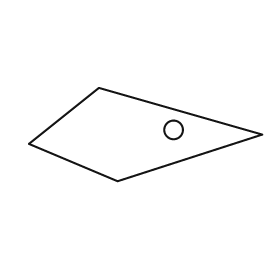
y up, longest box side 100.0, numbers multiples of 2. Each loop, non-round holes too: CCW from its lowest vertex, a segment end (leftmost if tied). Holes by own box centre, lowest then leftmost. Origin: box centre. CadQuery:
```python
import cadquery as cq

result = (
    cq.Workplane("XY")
    .moveTo(-12.0, -20.0)
    .lineTo(50.0, 0.0)
    .lineTo(-20.0, 20.0)
    .lineTo(-50.0, -4.0)
    .close()
    .moveTo(12.0, 2.0)
    .circle(4.0)
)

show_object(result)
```